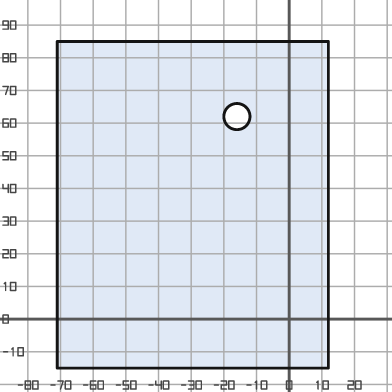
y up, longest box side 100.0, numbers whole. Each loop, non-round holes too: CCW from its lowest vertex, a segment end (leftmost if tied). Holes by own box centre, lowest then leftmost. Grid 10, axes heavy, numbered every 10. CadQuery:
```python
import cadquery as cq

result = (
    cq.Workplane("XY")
    .moveTo(-71.0, -15.0)
    .lineTo(12.0, -15.0)
    .lineTo(12.0, 85.0)
    .lineTo(-71.0, 85.0)
    .close()
    .moveTo(-16.0, 62.0)
    .circle(4.0)
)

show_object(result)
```